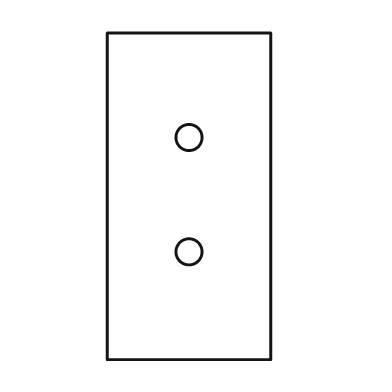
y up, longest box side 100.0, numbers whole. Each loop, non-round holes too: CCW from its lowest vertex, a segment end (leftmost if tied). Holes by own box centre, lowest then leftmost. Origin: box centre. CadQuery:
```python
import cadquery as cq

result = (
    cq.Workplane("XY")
    .moveTo(-25.0, -50.0)
    .lineTo(25.0, -50.0)
    .lineTo(25.0, 50.0)
    .lineTo(-25.0, 50.0)
    .close()
    .moveTo(0.0, -17.0)
    .circle(4.0)
    .moveTo(0.0, 18.0)
    .circle(4.0)
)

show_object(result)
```